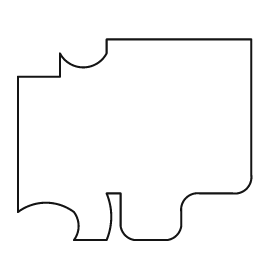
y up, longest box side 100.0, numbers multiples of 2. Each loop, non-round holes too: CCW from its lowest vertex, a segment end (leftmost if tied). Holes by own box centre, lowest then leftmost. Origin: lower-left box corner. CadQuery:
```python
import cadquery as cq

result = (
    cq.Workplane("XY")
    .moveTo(24.0, 0.0)
    .lineTo(38.0, 0.0)
    .threePointArc((40.0, 10.0), (38.0, 20.0))
    .lineTo(44.0, 20.0)
    .lineTo(44.0, 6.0)
    .threePointArc((46.0, 2.0), (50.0, 0.0))
    .lineTo(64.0, 0.0)
    .threePointArc((68.0, 2.0), (70.0, 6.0))
    .lineTo(70.0, 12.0)
    .threePointArc((72.0, 18.0), (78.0, 20.0))
    .lineTo(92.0, 20.0)
    .threePointArc((98.0, 22.0), (100.0, 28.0))
    .lineTo(100.0, 86.0)
    .lineTo(38.0, 86.0)
    .lineTo(38.0, 80.0)
    .threePointArc((28.0, 74.0), (18.0, 80.0))
    .lineTo(18.0, 70.0)
    .lineTo(0.0, 70.0)
    .lineTo(0.0, 12.0)
    .threePointArc((12.0, 16.0), (24.0, 12.0))
    .threePointArc((26.0, 6.0), (24.0, 0.0))
    .close()
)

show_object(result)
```